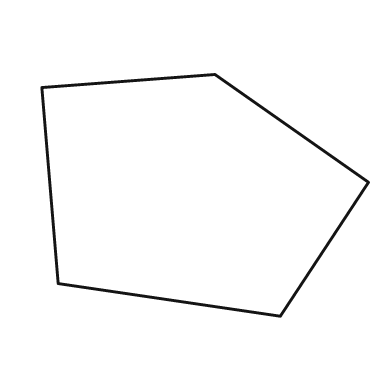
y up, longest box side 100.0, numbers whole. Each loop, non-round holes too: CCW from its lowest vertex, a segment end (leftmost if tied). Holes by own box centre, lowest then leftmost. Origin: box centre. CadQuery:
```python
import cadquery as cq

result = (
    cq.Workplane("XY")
    .moveTo(23.0, -37.0)
    .lineTo(50.0, 4.0)
    .lineTo(3.0, 37.0)
    .lineTo(-50.0, 33.0)
    .lineTo(-45.0, -27.0)
    .close()
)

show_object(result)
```